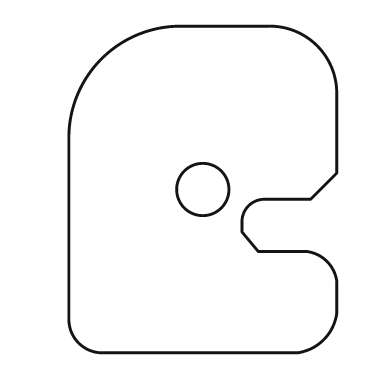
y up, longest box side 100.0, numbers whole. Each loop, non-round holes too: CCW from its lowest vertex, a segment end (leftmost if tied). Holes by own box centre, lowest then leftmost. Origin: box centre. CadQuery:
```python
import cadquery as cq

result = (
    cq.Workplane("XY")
    .moveTo(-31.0, -50.0)
    .lineTo(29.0, -50.0)
    .threePointArc((37.0, -46.0), (41.0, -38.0))
    .lineTo(41.0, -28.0)
    .threePointArc((38.0, -22.0), (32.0, -19.0))
    .lineTo(17.0, -19.0)
    .lineTo(12.0, -13.0)
    .lineTo(12.0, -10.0)
    .threePointArc((14.0, -5.0), (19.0, -3.0))
    .lineTo(33.0, -3.0)
    .lineTo(41.0, 5.0)
    .lineTo(41.0, 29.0)
    .threePointArc((35.0, 44.0), (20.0, 50.0))
    .lineTo(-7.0, 50.0)
    .threePointArc((-31.0, 40.0), (-41.0, 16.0))
    .lineTo(-41.0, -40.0)
    .threePointArc((-38.0, -47.0), (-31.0, -50.0))
    .close()
    .moveTo(0.0, 0.0)
    .circle(8.0)
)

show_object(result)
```